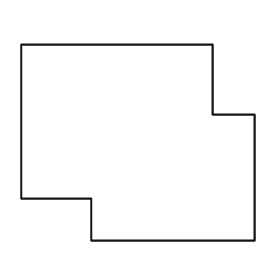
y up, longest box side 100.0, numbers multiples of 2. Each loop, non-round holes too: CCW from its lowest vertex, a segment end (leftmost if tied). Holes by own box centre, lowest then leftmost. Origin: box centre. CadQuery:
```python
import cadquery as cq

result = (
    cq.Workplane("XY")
    .moveTo(-20.0, -42.0)
    .lineTo(50.0, -42.0)
    .lineTo(50.0, 12.0)
    .lineTo(32.0, 12.0)
    .lineTo(32.0, 42.0)
    .lineTo(-50.0, 42.0)
    .lineTo(-50.0, -24.0)
    .lineTo(-20.0, -24.0)
    .close()
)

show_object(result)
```